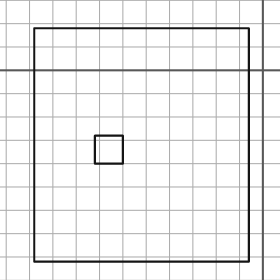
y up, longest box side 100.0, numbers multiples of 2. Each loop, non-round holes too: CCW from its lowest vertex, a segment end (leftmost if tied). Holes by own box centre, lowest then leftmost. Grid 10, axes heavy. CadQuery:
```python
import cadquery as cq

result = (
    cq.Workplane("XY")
    .moveTo(-98.0, -82.0)
    .lineTo(-6.0, -82.0)
    .lineTo(-6.0, 18.0)
    .lineTo(-98.0, 18.0)
    .close()
    .moveTo(-72.0, -40.0)
    .lineTo(-60.0, -40.0)
    .lineTo(-60.0, -28.0)
    .lineTo(-72.0, -28.0)
    .close()
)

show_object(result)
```